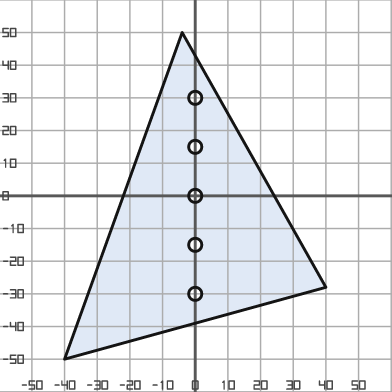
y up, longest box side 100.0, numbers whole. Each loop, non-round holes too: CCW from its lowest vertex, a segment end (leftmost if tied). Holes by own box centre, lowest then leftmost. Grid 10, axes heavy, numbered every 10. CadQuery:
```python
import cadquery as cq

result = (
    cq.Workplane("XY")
    .moveTo(-40.0, -50.0)
    .lineTo(40.0, -28.0)
    .lineTo(-4.0, 50.0)
    .close()
    .moveTo(0.0, -30.0)
    .circle(2.0)
    .moveTo(0.0, -15.0)
    .circle(2.0)
    .moveTo(0.0, 0.0)
    .circle(2.0)
    .moveTo(0.0, 15.0)
    .circle(2.0)
    .moveTo(0.0, 30.0)
    .circle(2.0)
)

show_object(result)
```